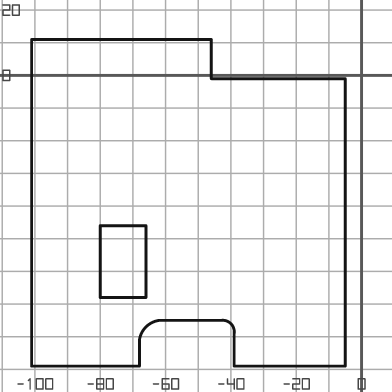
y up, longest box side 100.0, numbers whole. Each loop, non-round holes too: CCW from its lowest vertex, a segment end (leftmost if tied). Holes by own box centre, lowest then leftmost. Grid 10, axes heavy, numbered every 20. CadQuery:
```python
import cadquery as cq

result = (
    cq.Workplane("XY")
    .moveTo(-101.0, -89.0)
    .lineTo(-68.0, -89.0)
    .lineTo(-68.0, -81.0)
    .threePointArc((-66.0, -77.0), (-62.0, -75.0))
    .lineTo(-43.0, -75.0)
    .threePointArc((-40.0, -76.0), (-39.0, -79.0))
    .lineTo(-39.0, -89.0)
    .lineTo(-5.0, -89.0)
    .lineTo(-5.0, -1.0)
    .lineTo(-46.0, -1.0)
    .lineTo(-46.0, 11.0)
    .lineTo(-101.0, 11.0)
    .close()
    .moveTo(-80.0, -68.0)
    .lineTo(-66.0, -68.0)
    .lineTo(-66.0, -46.0)
    .lineTo(-80.0, -46.0)
    .close()
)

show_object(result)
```